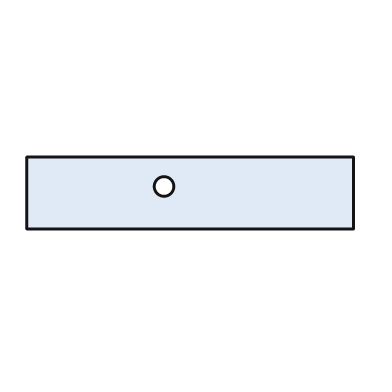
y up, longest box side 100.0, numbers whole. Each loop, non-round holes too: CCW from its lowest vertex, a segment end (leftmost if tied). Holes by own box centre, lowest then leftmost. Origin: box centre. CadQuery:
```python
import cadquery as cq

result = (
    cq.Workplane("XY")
    .moveTo(-50.0, -11.0)
    .lineTo(50.0, -11.0)
    .lineTo(50.0, 11.0)
    .lineTo(-50.0, 11.0)
    .close()
    .moveTo(-8.0, 2.0)
    .circle(3.0)
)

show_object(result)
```